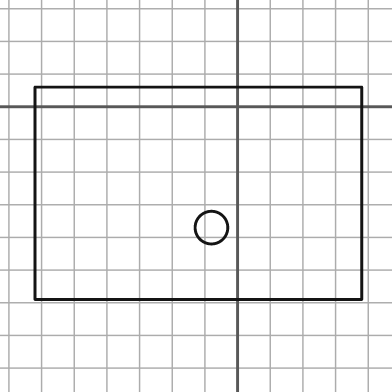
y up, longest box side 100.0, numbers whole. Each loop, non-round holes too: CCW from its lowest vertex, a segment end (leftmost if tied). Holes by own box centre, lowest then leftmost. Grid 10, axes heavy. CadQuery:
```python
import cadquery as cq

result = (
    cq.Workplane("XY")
    .moveTo(-62.0, -59.0)
    .lineTo(38.0, -59.0)
    .lineTo(38.0, 6.0)
    .lineTo(-62.0, 6.0)
    .close()
    .moveTo(-8.0, -37.0)
    .circle(5.0)
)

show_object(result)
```